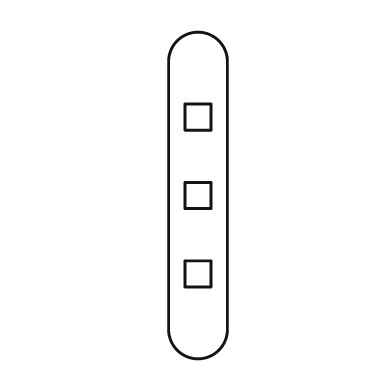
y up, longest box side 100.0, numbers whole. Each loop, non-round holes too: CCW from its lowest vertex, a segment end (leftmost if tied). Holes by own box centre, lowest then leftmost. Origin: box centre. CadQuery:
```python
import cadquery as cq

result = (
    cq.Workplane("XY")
    .moveTo(-9.0, -41.0)
    .threePointArc((0.0, -50.0), (9.0, -41.0))
    .lineTo(9.0, 41.0)
    .threePointArc((0.0, 50.0), (-9.0, 41.0))
    .close()
    .moveTo(-4.0, -28.0)
    .lineTo(4.0, -28.0)
    .lineTo(4.0, -20.0)
    .lineTo(-4.0, -20.0)
    .close()
    .moveTo(-4.0, -4.0)
    .lineTo(4.0, -4.0)
    .lineTo(4.0, 4.0)
    .lineTo(-4.0, 4.0)
    .close()
    .moveTo(-4.0, 20.0)
    .lineTo(4.0, 20.0)
    .lineTo(4.0, 28.0)
    .lineTo(-4.0, 28.0)
    .close()
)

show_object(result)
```